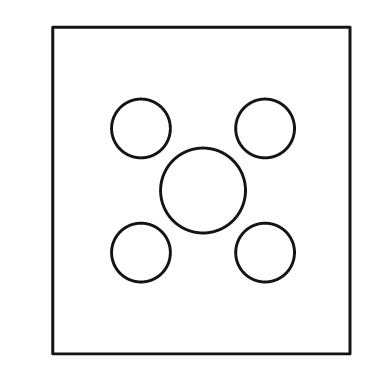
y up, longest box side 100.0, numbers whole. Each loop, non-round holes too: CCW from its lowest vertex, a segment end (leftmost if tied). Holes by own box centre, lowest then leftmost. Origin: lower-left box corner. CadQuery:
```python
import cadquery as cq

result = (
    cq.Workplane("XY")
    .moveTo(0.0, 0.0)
    .lineTo(91.0, 0.0)
    .lineTo(91.0, 100.0)
    .lineTo(0.0, 100.0)
    .close()
    .moveTo(27.0, 31.0)
    .circle(9.0)
    .moveTo(65.0, 31.0)
    .circle(9.0)
    .moveTo(46.0, 50.0)
    .circle(13.0)
    .moveTo(27.0, 69.0)
    .circle(9.0)
    .moveTo(65.0, 69.0)
    .circle(9.0)
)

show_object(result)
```